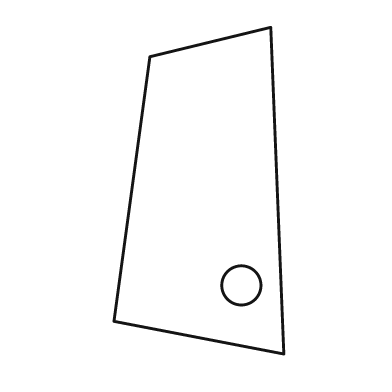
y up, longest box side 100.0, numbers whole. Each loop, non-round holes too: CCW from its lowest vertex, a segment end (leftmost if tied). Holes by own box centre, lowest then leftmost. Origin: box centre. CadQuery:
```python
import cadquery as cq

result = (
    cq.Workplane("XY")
    .moveTo(26.0, -50.0)
    .lineTo(22.0, 50.0)
    .lineTo(-15.0, 41.0)
    .lineTo(-26.0, -40.0)
    .close()
    .moveTo(13.0, -29.0)
    .circle(6.0)
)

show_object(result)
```